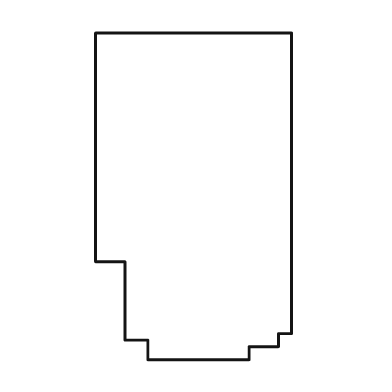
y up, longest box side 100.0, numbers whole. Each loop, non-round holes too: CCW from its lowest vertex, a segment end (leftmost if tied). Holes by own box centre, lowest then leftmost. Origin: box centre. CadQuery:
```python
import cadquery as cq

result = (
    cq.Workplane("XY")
    .moveTo(-14.0, -50.0)
    .lineTo(17.0, -50.0)
    .lineTo(17.0, -46.0)
    .lineTo(26.0, -46.0)
    .lineTo(26.0, -42.0)
    .lineTo(30.0, -42.0)
    .lineTo(30.0, 50.0)
    .lineTo(-30.0, 50.0)
    .lineTo(-30.0, -20.0)
    .lineTo(-21.0, -20.0)
    .lineTo(-21.0, -44.0)
    .lineTo(-14.0, -44.0)
    .close()
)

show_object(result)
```